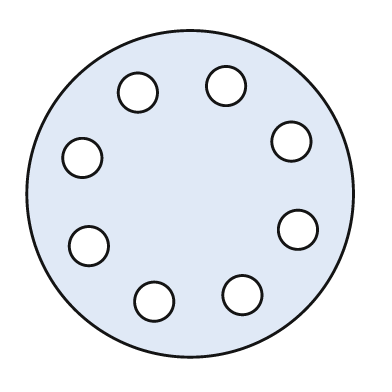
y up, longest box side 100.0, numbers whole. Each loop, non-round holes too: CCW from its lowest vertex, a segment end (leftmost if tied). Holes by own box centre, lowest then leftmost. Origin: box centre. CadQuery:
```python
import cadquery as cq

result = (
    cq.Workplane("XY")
    .moveTo(0.0, 0.0)
    .circle(50.0)
    .moveTo(-11.0, -33.0)
    .circle(6.0)
    .moveTo(16.0, -31.0)
    .circle(6.0)
    .moveTo(-31.0, -16.0)
    .circle(6.0)
    .moveTo(33.0, -11.0)
    .circle(6.0)
    .moveTo(-33.0, 11.0)
    .circle(6.0)
    .moveTo(31.0, 16.0)
    .circle(6.0)
    .moveTo(-16.0, 31.0)
    .circle(6.0)
    .moveTo(11.0, 33.0)
    .circle(6.0)
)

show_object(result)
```